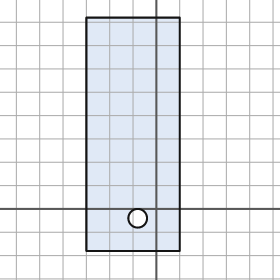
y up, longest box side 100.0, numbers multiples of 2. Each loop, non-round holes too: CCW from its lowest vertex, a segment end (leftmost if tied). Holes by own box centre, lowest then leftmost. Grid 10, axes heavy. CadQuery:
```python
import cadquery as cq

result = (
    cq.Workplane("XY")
    .moveTo(-30.0, -18.0)
    .lineTo(10.0, -18.0)
    .lineTo(10.0, 82.0)
    .lineTo(-30.0, 82.0)
    .close()
    .moveTo(-8.0, -4.0)
    .circle(4.0)
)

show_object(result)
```